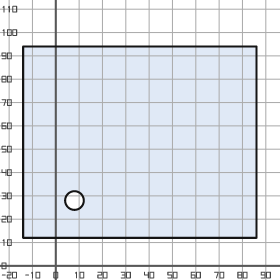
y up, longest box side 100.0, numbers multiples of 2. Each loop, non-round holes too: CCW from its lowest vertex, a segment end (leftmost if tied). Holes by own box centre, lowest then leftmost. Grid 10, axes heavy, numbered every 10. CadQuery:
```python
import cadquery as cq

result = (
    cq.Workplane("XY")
    .moveTo(-14.0, 12.0)
    .lineTo(86.0, 12.0)
    .lineTo(86.0, 94.0)
    .lineTo(-14.0, 94.0)
    .close()
    .moveTo(8.0, 28.0)
    .circle(4.0)
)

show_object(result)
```